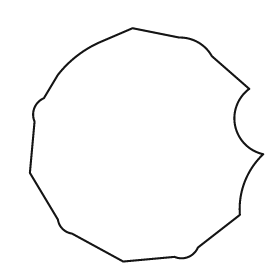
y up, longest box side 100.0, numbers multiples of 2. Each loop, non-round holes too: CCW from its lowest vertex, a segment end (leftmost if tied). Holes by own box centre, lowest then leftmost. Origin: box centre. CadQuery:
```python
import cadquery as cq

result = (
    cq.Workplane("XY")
    .moveTo(-10.0, -50.0)
    .lineTo(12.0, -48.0)
    .threePointArc((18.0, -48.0), (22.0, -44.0))
    .lineTo(40.0, -30.0)
    .threePointArc((42.0, -16.0), (50.0, -4.0))
    .threePointArc((38.0, 8.0), (44.0, 24.0))
    .lineTo(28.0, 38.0)
    .threePointArc((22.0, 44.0), (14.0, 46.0))
    .lineTo(-6.0, 50.0)
    .lineTo(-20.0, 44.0)
    .threePointArc((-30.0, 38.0), (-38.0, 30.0))
    .lineTo(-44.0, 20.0)
    .threePointArc((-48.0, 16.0), (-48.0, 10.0))
    .lineTo(-50.0, -12.0)
    .lineTo(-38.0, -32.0)
    .threePointArc((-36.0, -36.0), (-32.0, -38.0))
    .close()
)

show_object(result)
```